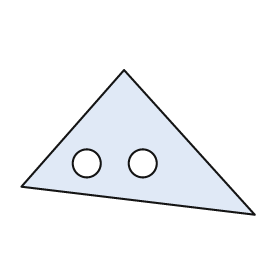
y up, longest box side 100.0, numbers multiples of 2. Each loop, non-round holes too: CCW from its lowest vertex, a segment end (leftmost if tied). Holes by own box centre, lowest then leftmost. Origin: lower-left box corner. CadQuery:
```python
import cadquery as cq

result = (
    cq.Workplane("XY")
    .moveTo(100.0, 0.0)
    .lineTo(44.0, 62.0)
    .lineTo(0.0, 12.0)
    .close()
    .moveTo(28.0, 22.0)
    .circle(6.0)
    .moveTo(52.0, 22.0)
    .circle(6.0)
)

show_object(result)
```